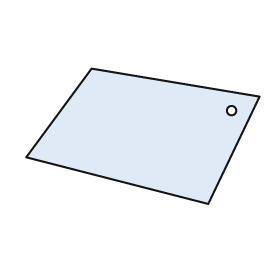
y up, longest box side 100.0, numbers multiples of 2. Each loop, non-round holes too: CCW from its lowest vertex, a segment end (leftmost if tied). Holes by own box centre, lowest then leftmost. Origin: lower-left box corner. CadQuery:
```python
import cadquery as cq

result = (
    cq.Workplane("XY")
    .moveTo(78.0, 0.0)
    .lineTo(100.0, 46.0)
    .lineTo(28.0, 58.0)
    .lineTo(0.0, 20.0)
    .close()
    .moveTo(88.0, 40.0)
    .circle(2.0)
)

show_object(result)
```